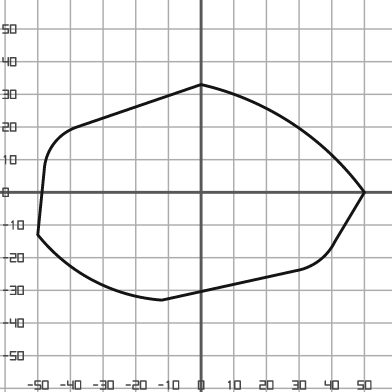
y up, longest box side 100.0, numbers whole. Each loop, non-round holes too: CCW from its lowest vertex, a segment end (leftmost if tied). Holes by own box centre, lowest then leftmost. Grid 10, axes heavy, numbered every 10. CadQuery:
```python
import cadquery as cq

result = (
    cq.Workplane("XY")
    .moveTo(-12.0, -33.0)
    .lineTo(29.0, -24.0)
    .threePointArc((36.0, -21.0), (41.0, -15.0))
    .lineTo(50.0, 0.0)
    .threePointArc((28.0, 21.0), (0.0, 33.0))
    .lineTo(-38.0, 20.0)
    .threePointArc((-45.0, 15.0), (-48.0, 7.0))
    .lineTo(-50.0, -13.0)
    .threePointArc((-33.0, -27.0), (-12.0, -33.0))
    .close()
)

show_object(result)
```